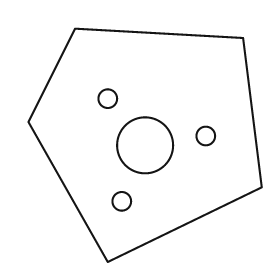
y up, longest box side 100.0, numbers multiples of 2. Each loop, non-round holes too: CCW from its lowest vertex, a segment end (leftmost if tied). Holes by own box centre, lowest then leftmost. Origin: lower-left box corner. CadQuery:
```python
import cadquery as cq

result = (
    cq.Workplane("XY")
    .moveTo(34.0, 0.0)
    .lineTo(100.0, 32.0)
    .lineTo(92.0, 96.0)
    .lineTo(20.0, 100.0)
    .lineTo(0.0, 60.0)
    .close()
    .moveTo(40.0, 26.0)
    .circle(4.0)
    .moveTo(50.0, 50.0)
    .circle(12.0)
    .moveTo(76.0, 54.0)
    .circle(4.0)
    .moveTo(34.0, 70.0)
    .circle(4.0)
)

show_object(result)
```